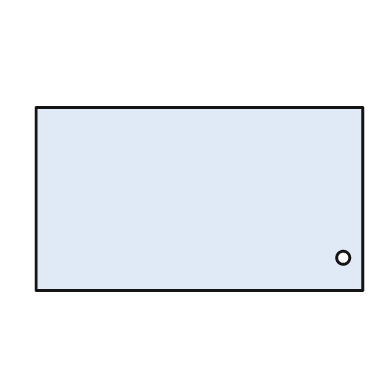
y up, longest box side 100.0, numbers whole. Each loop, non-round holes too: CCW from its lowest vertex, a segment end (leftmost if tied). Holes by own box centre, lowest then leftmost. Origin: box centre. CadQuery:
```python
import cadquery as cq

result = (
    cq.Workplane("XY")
    .moveTo(-50.0, -28.0)
    .lineTo(50.0, -28.0)
    .lineTo(50.0, 28.0)
    .lineTo(-50.0, 28.0)
    .close()
    .moveTo(44.0, -18.0)
    .circle(2.0)
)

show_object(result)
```